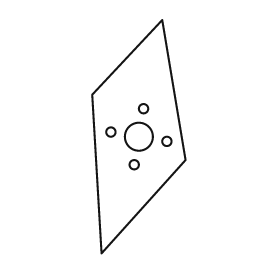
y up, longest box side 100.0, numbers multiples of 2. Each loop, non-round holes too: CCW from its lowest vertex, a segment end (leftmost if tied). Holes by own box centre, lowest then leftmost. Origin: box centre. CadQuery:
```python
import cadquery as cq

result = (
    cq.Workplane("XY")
    .moveTo(-16.0, -50.0)
    .lineTo(20.0, -10.0)
    .lineTo(10.0, 50.0)
    .lineTo(-20.0, 18.0)
    .close()
    .moveTo(-2.0, -12.0)
    .circle(2.0)
    .moveTo(12.0, -2.0)
    .circle(2.0)
    .moveTo(0.0, 0.0)
    .circle(6.0)
    .moveTo(-12.0, 2.0)
    .circle(2.0)
    .moveTo(2.0, 12.0)
    .circle(2.0)
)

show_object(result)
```